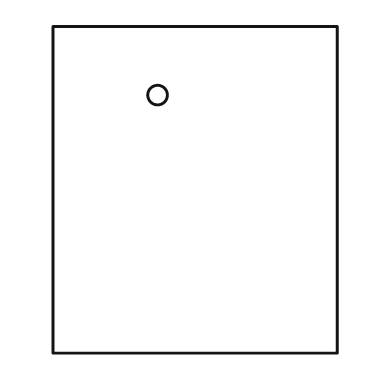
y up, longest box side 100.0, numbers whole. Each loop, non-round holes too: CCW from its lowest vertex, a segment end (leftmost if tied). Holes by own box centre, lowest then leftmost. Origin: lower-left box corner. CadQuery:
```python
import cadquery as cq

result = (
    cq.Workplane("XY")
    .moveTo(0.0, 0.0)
    .lineTo(87.0, 0.0)
    .lineTo(87.0, 100.0)
    .lineTo(0.0, 100.0)
    .close()
    .moveTo(32.0, 79.0)
    .circle(3.0)
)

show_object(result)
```